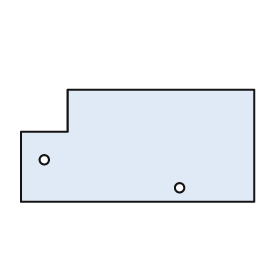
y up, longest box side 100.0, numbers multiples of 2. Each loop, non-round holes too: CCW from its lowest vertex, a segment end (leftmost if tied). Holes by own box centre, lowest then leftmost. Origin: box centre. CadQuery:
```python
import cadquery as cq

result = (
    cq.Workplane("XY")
    .moveTo(-50.0, -24.0)
    .lineTo(50.0, -24.0)
    .lineTo(50.0, 24.0)
    .lineTo(-30.0, 24.0)
    .lineTo(-30.0, 6.0)
    .lineTo(-50.0, 6.0)
    .close()
    .moveTo(18.0, -18.0)
    .circle(2.0)
    .moveTo(-40.0, -6.0)
    .circle(2.0)
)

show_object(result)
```